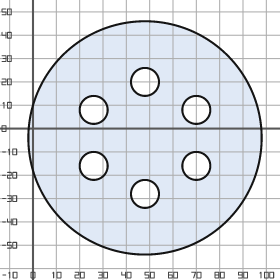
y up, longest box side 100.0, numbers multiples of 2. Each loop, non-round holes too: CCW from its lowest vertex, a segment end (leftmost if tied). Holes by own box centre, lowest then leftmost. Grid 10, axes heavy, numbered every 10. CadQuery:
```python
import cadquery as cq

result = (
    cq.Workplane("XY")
    .moveTo(48.0, -4.0)
    .circle(50.0)
    .moveTo(48.0, -28.0)
    .circle(6.0)
    .moveTo(26.0, -16.0)
    .circle(6.0)
    .moveTo(70.0, -16.0)
    .circle(6.0)
    .moveTo(26.0, 8.0)
    .circle(6.0)
    .moveTo(70.0, 8.0)
    .circle(6.0)
    .moveTo(48.0, 20.0)
    .circle(6.0)
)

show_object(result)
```